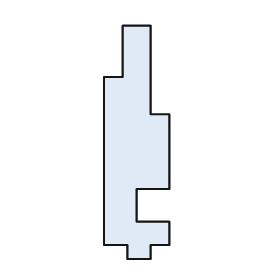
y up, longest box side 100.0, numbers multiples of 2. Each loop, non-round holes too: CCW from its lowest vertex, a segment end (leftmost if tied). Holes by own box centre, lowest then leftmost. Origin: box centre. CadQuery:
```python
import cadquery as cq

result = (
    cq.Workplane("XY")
    .moveTo(-4.0, -50.0)
    .lineTo(6.0, -50.0)
    .lineTo(6.0, -44.0)
    .lineTo(14.0, -44.0)
    .lineTo(14.0, -34.0)
    .lineTo(0.0, -34.0)
    .lineTo(0.0, -20.0)
    .lineTo(14.0, -20.0)
    .lineTo(14.0, 12.0)
    .lineTo(6.0, 12.0)
    .lineTo(6.0, 50.0)
    .lineTo(-6.0, 50.0)
    .lineTo(-6.0, 28.0)
    .lineTo(-14.0, 28.0)
    .lineTo(-14.0, -44.0)
    .lineTo(-4.0, -44.0)
    .close()
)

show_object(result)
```